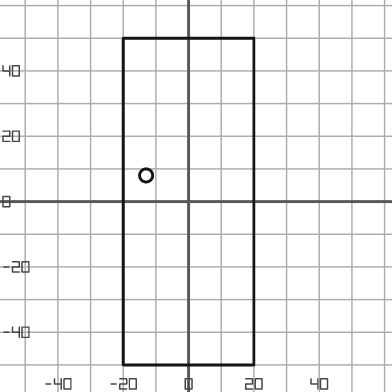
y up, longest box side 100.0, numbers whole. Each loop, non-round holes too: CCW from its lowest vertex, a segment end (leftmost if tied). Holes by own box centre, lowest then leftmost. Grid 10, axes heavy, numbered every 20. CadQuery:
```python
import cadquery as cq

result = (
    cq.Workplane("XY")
    .moveTo(-20.0, -50.0)
    .lineTo(20.0, -50.0)
    .lineTo(20.0, 50.0)
    .lineTo(-20.0, 50.0)
    .close()
    .moveTo(-13.0, 8.0)
    .circle(2.0)
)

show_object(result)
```